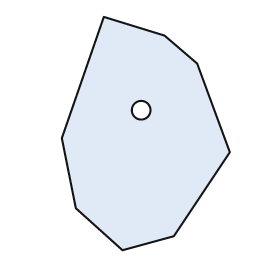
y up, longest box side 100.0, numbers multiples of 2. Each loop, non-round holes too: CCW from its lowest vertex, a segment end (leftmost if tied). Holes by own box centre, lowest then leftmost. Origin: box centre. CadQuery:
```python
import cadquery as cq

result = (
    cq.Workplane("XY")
    .moveTo(-10.0, -50.0)
    .lineTo(12.0, -44.0)
    .lineTo(36.0, -8.0)
    .lineTo(22.0, 30.0)
    .lineTo(8.0, 42.0)
    .lineTo(-18.0, 50.0)
    .lineTo(-36.0, -2.0)
    .lineTo(-30.0, -32.0)
    .close()
    .moveTo(-2.0, 10.0)
    .circle(4.0)
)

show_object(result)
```